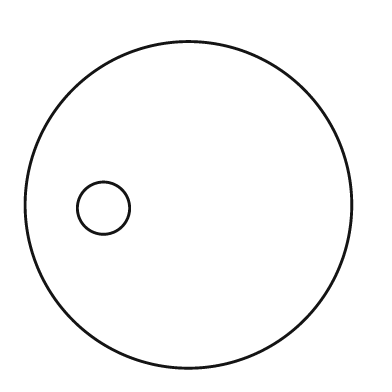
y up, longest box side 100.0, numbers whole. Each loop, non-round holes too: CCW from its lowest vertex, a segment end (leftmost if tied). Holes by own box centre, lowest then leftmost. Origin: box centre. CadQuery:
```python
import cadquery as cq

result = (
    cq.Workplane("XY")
    .moveTo(0.0, 0.0)
    .circle(50.0)
    .moveTo(-26.0, -1.0)
    .circle(8.0)
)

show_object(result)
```